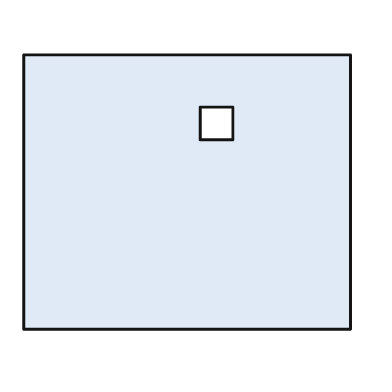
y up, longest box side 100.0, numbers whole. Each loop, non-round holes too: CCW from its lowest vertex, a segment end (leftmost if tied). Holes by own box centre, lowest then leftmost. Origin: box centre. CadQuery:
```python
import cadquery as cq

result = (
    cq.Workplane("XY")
    .moveTo(-50.0, -42.0)
    .lineTo(50.0, -42.0)
    .lineTo(50.0, 42.0)
    .lineTo(-50.0, 42.0)
    .close()
    .moveTo(4.0, 16.0)
    .lineTo(14.0, 16.0)
    .lineTo(14.0, 26.0)
    .lineTo(4.0, 26.0)
    .close()
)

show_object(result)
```